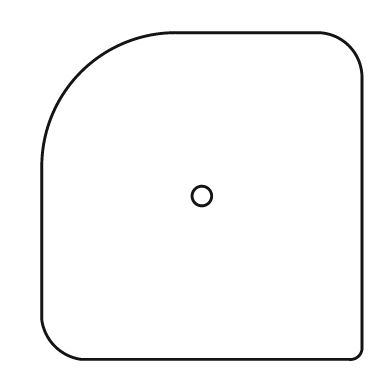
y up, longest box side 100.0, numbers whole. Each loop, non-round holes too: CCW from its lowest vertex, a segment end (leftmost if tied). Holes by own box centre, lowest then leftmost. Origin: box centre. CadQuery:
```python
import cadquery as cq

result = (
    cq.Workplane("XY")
    .moveTo(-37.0, -50.0)
    .lineTo(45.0, -50.0)
    .threePointArc((48.0, -49.0), (49.0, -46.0))
    .lineTo(49.0, 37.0)
    .threePointArc((45.0, 46.0), (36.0, 50.0))
    .lineTo(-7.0, 50.0)
    .threePointArc((-37.0, 38.0), (-49.0, 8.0))
    .lineTo(-49.0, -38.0)
    .threePointArc((-45.0, -46.0), (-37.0, -50.0))
    .close()
    .moveTo(0.0, 0.0)
    .circle(3.0)
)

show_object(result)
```